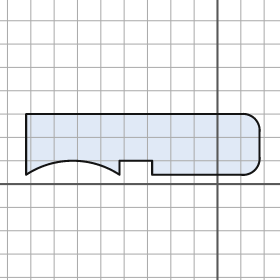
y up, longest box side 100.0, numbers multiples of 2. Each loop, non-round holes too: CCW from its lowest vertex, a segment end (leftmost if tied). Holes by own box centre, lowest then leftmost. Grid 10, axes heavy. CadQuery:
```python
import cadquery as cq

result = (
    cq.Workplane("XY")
    .moveTo(-82.0, 4.0)
    .threePointArc((-62.0, 10.0), (-42.0, 4.0))
    .lineTo(-42.0, 10.0)
    .lineTo(-28.0, 10.0)
    .lineTo(-28.0, 4.0)
    .lineTo(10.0, 4.0)
    .threePointArc((16.0, 6.0), (18.0, 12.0))
    .lineTo(18.0, 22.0)
    .threePointArc((16.0, 28.0), (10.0, 30.0))
    .lineTo(-82.0, 30.0)
    .close()
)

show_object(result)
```